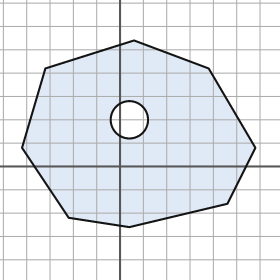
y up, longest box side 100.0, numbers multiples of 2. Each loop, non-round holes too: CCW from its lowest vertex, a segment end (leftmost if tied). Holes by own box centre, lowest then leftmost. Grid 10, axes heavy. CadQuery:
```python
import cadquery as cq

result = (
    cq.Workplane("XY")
    .moveTo(4.0, -26.0)
    .lineTo(46.0, -16.0)
    .lineTo(58.0, 8.0)
    .lineTo(38.0, 42.0)
    .lineTo(6.0, 54.0)
    .lineTo(-32.0, 42.0)
    .lineTo(-42.0, 8.0)
    .lineTo(-22.0, -22.0)
    .close()
    .moveTo(4.0, 20.0)
    .circle(8.0)
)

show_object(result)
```